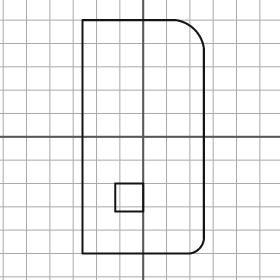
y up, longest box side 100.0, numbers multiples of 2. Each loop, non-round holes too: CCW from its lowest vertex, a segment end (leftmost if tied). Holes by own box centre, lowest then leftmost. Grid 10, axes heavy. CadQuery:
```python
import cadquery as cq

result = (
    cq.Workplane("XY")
    .moveTo(-26.0, -50.0)
    .lineTo(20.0, -50.0)
    .threePointArc((24.0, -48.0), (26.0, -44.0))
    .lineTo(26.0, 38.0)
    .threePointArc((22.0, 46.0), (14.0, 50.0))
    .lineTo(-26.0, 50.0)
    .close()
    .moveTo(-12.0, -32.0)
    .lineTo(0.0, -32.0)
    .lineTo(0.0, -20.0)
    .lineTo(-12.0, -20.0)
    .close()
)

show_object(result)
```